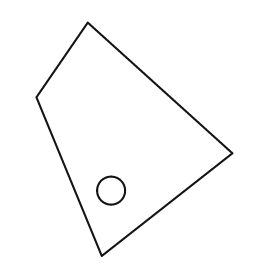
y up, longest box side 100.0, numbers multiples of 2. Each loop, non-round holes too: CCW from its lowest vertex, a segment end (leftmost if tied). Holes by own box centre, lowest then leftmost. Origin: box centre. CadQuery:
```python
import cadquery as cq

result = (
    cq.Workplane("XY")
    .moveTo(-14.0, -50.0)
    .lineTo(42.0, -6.0)
    .lineTo(-20.0, 50.0)
    .lineTo(-42.0, 18.0)
    .close()
    .moveTo(-10.0, -22.0)
    .circle(6.0)
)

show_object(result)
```